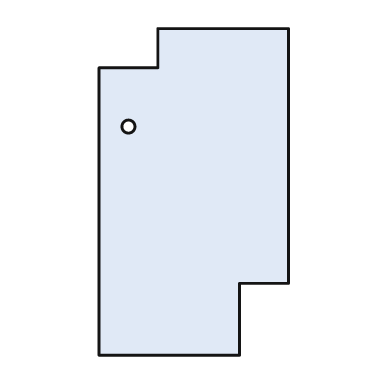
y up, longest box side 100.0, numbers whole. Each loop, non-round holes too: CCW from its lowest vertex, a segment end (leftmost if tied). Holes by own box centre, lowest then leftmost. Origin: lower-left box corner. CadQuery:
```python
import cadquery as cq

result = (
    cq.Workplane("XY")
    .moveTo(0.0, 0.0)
    .lineTo(43.0, 0.0)
    .lineTo(43.0, 22.0)
    .lineTo(58.0, 22.0)
    .lineTo(58.0, 100.0)
    .lineTo(18.0, 100.0)
    .lineTo(18.0, 88.0)
    .lineTo(0.0, 88.0)
    .close()
    .moveTo(9.0, 70.0)
    .circle(2.0)
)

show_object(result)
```